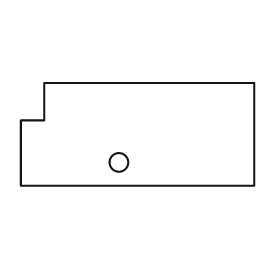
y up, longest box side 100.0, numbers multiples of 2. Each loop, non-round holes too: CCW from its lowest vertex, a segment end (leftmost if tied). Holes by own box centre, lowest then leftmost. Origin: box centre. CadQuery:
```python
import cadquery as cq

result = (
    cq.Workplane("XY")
    .moveTo(-50.0, -22.0)
    .lineTo(50.0, -22.0)
    .lineTo(50.0, 22.0)
    .lineTo(-40.0, 22.0)
    .lineTo(-40.0, 6.0)
    .lineTo(-50.0, 6.0)
    .close()
    .moveTo(-8.0, -12.0)
    .circle(4.0)
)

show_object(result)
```